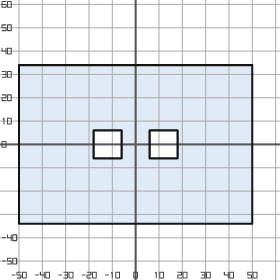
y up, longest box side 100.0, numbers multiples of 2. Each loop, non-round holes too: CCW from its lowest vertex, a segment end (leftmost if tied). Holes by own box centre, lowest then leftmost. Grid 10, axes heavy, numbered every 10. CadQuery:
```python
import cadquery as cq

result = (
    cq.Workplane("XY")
    .moveTo(-50.0, -34.0)
    .lineTo(50.0, -34.0)
    .lineTo(50.0, 34.0)
    .lineTo(-50.0, 34.0)
    .close()
    .moveTo(-18.0, -6.0)
    .lineTo(-6.0, -6.0)
    .lineTo(-6.0, 6.0)
    .lineTo(-18.0, 6.0)
    .close()
    .moveTo(6.0, -6.0)
    .lineTo(18.0, -6.0)
    .lineTo(18.0, 6.0)
    .lineTo(6.0, 6.0)
    .close()
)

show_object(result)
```